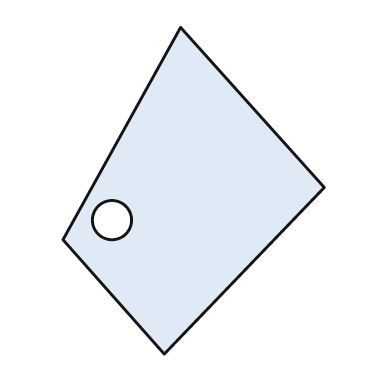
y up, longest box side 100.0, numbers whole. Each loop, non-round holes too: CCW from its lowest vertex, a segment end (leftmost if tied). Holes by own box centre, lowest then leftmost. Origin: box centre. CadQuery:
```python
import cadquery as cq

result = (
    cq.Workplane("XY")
    .moveTo(-9.0, -50.0)
    .lineTo(40.0, 1.0)
    .lineTo(-4.0, 50.0)
    .lineTo(-40.0, -15.0)
    .close()
    .moveTo(-25.0, -9.0)
    .circle(6.0)
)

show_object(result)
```